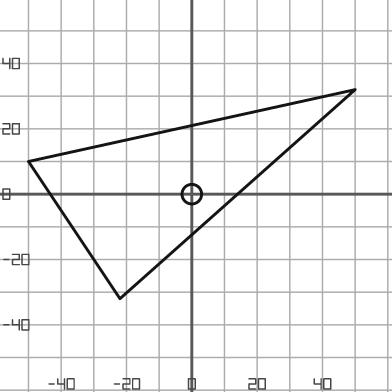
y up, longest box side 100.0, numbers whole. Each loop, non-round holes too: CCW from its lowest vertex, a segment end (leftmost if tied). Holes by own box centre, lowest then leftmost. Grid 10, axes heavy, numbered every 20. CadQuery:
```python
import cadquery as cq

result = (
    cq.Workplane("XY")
    .moveTo(-22.0, -32.0)
    .lineTo(50.0, 32.0)
    .lineTo(-50.0, 10.0)
    .close()
    .moveTo(0.0, 0.0)
    .circle(3.0)
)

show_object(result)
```